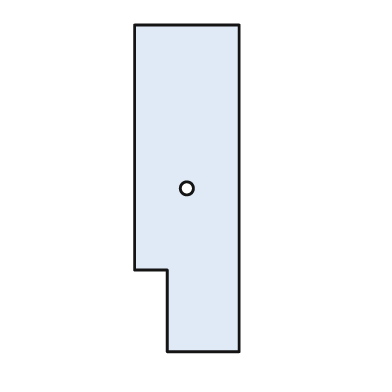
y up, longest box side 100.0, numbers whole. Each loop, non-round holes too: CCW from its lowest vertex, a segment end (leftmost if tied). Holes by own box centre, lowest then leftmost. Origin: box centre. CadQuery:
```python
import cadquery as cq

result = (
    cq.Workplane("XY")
    .moveTo(-6.0, -50.0)
    .lineTo(16.0, -50.0)
    .lineTo(16.0, 50.0)
    .lineTo(-16.0, 50.0)
    .lineTo(-16.0, -25.0)
    .lineTo(-6.0, -25.0)
    .close()
    .moveTo(0.0, 0.0)
    .circle(2.0)
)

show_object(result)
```